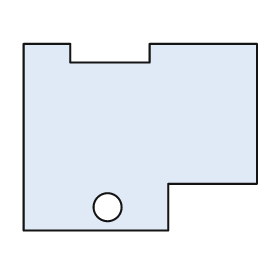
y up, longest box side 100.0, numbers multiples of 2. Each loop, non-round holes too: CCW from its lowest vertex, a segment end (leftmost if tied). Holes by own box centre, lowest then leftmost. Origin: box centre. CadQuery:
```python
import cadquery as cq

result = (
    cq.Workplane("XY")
    .moveTo(-50.0, -40.0)
    .lineTo(12.0, -40.0)
    .lineTo(12.0, -20.0)
    .lineTo(50.0, -20.0)
    .lineTo(50.0, 40.0)
    .lineTo(4.0, 40.0)
    .lineTo(4.0, 32.0)
    .lineTo(-30.0, 32.0)
    .lineTo(-30.0, 40.0)
    .lineTo(-50.0, 40.0)
    .close()
    .moveTo(-14.0, -30.0)
    .circle(6.0)
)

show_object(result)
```